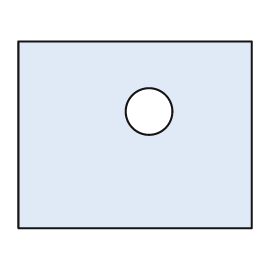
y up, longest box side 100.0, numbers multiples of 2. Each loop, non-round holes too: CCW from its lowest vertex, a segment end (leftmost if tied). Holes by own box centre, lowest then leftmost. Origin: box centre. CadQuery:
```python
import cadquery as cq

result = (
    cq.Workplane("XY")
    .moveTo(-50.0, -40.0)
    .lineTo(50.0, -40.0)
    .lineTo(50.0, 40.0)
    .lineTo(-50.0, 40.0)
    .close()
    .moveTo(6.0, 10.0)
    .circle(10.0)
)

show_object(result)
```